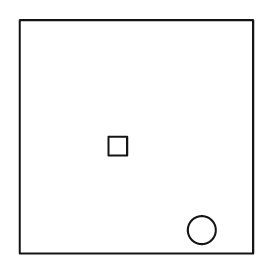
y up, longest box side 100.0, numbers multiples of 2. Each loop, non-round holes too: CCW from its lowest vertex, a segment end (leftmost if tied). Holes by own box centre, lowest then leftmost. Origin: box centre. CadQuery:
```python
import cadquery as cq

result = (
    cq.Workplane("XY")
    .moveTo(-50.0, -50.0)
    .lineTo(50.0, -50.0)
    .lineTo(50.0, 50.0)
    .lineTo(-50.0, 50.0)
    .close()
    .moveTo(28.0, -40.0)
    .circle(6.0)
    .moveTo(-12.0, -8.0)
    .lineTo(-4.0, -8.0)
    .lineTo(-4.0, 0.0)
    .lineTo(-12.0, 0.0)
    .close()
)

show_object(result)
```